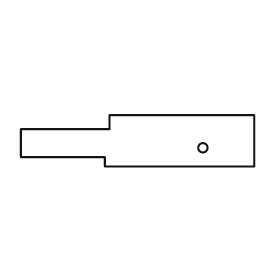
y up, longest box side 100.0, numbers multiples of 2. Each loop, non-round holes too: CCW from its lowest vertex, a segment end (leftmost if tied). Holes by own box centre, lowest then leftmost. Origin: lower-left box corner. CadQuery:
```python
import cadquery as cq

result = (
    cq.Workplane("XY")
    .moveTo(36.0, 0.0)
    .lineTo(100.0, 0.0)
    .lineTo(100.0, 22.0)
    .lineTo(38.0, 22.0)
    .lineTo(38.0, 16.0)
    .lineTo(0.0, 16.0)
    .lineTo(0.0, 4.0)
    .lineTo(36.0, 4.0)
    .close()
    .moveTo(78.0, 8.0)
    .circle(2.0)
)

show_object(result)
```